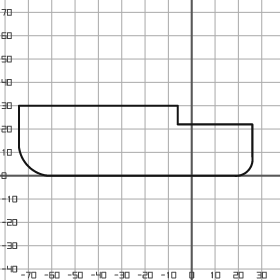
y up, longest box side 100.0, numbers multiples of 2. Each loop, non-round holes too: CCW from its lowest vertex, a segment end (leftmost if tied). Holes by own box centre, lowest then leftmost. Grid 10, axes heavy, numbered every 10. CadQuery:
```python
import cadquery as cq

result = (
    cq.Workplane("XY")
    .moveTo(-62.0, 0.0)
    .lineTo(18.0, 0.0)
    .threePointArc((24.0, 2.0), (26.0, 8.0))
    .lineTo(26.0, 22.0)
    .lineTo(-6.0, 22.0)
    .lineTo(-6.0, 30.0)
    .lineTo(-74.0, 30.0)
    .lineTo(-74.0, 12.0)
    .threePointArc((-70.0, 4.0), (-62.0, 0.0))
    .close()
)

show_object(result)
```